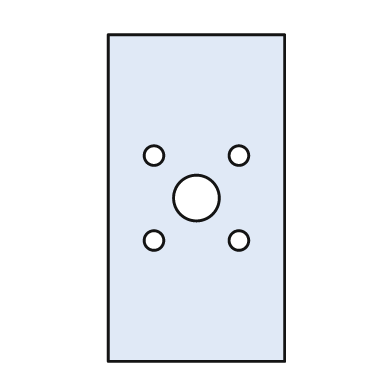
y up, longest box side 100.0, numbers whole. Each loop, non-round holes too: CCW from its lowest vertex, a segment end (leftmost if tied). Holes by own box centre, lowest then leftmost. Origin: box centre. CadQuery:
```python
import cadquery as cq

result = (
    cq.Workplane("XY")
    .moveTo(-27.0, -50.0)
    .lineTo(27.0, -50.0)
    .lineTo(27.0, 50.0)
    .lineTo(-27.0, 50.0)
    .close()
    .moveTo(-13.0, -13.0)
    .circle(3.0)
    .moveTo(13.0, -13.0)
    .circle(3.0)
    .moveTo(0.0, 0.0)
    .circle(7.0)
    .moveTo(-13.0, 13.0)
    .circle(3.0)
    .moveTo(13.0, 13.0)
    .circle(3.0)
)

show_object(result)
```